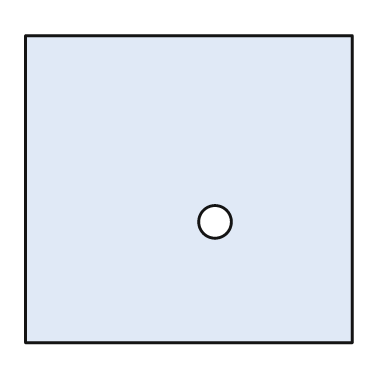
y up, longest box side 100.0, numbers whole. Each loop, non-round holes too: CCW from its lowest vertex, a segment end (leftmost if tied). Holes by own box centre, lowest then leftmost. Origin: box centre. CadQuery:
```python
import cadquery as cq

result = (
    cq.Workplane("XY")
    .moveTo(-50.0, -47.0)
    .lineTo(50.0, -47.0)
    .lineTo(50.0, 47.0)
    .lineTo(-50.0, 47.0)
    .close()
    .moveTo(8.0, -10.0)
    .circle(5.0)
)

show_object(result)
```